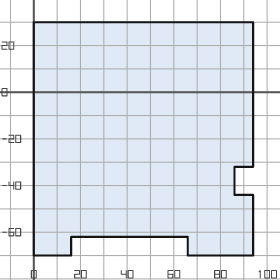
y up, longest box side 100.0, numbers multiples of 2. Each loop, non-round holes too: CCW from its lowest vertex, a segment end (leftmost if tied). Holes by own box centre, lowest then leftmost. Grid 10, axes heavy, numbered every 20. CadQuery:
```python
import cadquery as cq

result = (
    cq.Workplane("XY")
    .moveTo(0.0, -70.0)
    .lineTo(16.0, -70.0)
    .lineTo(16.0, -62.0)
    .lineTo(66.0, -62.0)
    .lineTo(66.0, -70.0)
    .lineTo(94.0, -70.0)
    .lineTo(94.0, -44.0)
    .lineTo(86.0, -44.0)
    .lineTo(86.0, -32.0)
    .lineTo(94.0, -32.0)
    .lineTo(94.0, 30.0)
    .lineTo(0.0, 30.0)
    .close()
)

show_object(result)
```